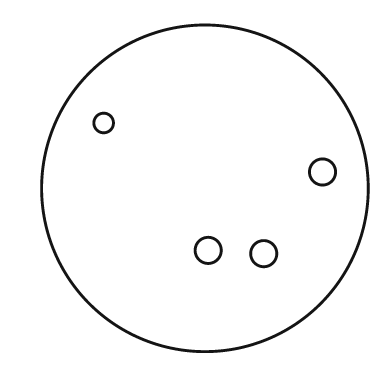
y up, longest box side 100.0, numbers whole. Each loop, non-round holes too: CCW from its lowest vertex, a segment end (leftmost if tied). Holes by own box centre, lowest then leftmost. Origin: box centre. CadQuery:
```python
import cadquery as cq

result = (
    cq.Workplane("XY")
    .moveTo(0.0, 0.0)
    .circle(50.0)
    .moveTo(18.0, -20.0)
    .circle(4.0)
    .moveTo(1.0, -19.0)
    .circle(4.0)
    .moveTo(36.0, 5.0)
    .circle(4.0)
    .moveTo(-31.0, 20.0)
    .circle(3.0)
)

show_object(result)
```